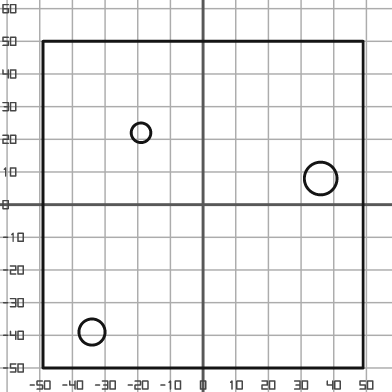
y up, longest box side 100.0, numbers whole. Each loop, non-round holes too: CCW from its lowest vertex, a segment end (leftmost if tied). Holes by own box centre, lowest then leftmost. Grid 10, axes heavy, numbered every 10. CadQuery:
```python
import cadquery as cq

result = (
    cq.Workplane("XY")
    .moveTo(-49.0, -50.0)
    .lineTo(49.0, -50.0)
    .lineTo(49.0, 50.0)
    .lineTo(-49.0, 50.0)
    .close()
    .moveTo(-34.0, -39.0)
    .circle(4.0)
    .moveTo(36.0, 8.0)
    .circle(5.0)
    .moveTo(-19.0, 22.0)
    .circle(3.0)
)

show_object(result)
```